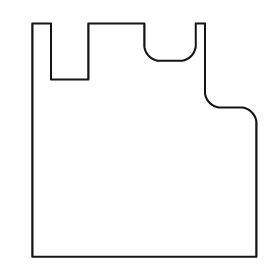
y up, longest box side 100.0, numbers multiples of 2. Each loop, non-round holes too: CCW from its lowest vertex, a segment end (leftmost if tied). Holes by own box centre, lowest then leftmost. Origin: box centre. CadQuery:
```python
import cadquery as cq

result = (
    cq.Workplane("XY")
    .moveTo(-48.0, -50.0)
    .lineTo(48.0, -50.0)
    .lineTo(48.0, 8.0)
    .threePointArc((46.0, 12.0), (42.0, 14.0))
    .lineTo(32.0, 14.0)
    .threePointArc((28.0, 16.0), (26.0, 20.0))
    .lineTo(26.0, 50.0)
    .lineTo(22.0, 50.0)
    .lineTo(22.0, 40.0)
    .threePointArc((20.0, 36.0), (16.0, 34.0))
    .lineTo(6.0, 34.0)
    .threePointArc((2.0, 36.0), (0.0, 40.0))
    .lineTo(0.0, 50.0)
    .lineTo(-24.0, 50.0)
    .lineTo(-24.0, 26.0)
    .lineTo(-40.0, 26.0)
    .lineTo(-40.0, 50.0)
    .lineTo(-48.0, 50.0)
    .close()
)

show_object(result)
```